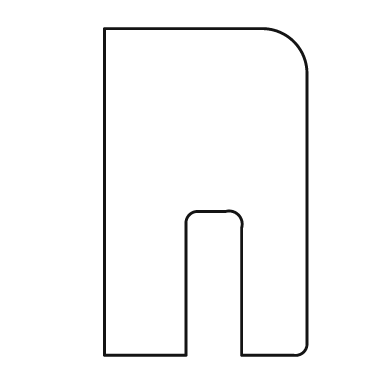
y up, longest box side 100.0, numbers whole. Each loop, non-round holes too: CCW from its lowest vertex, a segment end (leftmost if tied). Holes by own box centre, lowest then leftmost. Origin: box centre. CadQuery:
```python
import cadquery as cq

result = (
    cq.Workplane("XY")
    .moveTo(-31.0, -50.0)
    .lineTo(-6.0, -50.0)
    .lineTo(-6.0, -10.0)
    .threePointArc((-5.0, -7.0), (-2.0, -6.0))
    .lineTo(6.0, -6.0)
    .threePointArc((10.0, -7.0), (11.0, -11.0))
    .lineTo(11.0, -50.0)
    .lineTo(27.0, -50.0)
    .threePointArc((30.0, -49.0), (31.0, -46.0))
    .lineTo(31.0, 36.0)
    .threePointArc((27.0, 46.0), (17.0, 50.0))
    .lineTo(-31.0, 50.0)
    .close()
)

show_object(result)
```